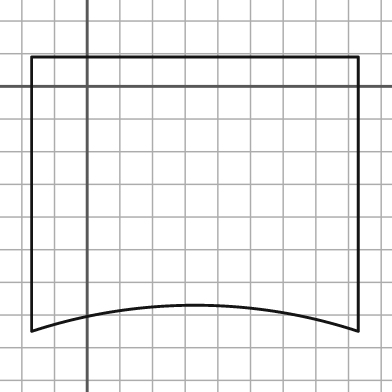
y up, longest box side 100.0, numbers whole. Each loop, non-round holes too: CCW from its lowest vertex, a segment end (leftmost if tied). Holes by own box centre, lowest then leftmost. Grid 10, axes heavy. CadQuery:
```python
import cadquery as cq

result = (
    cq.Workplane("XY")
    .moveTo(-17.0, -75.0)
    .threePointArc((33.0, -67.0), (83.0, -75.0))
    .lineTo(83.0, 9.0)
    .lineTo(-17.0, 9.0)
    .close()
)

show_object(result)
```